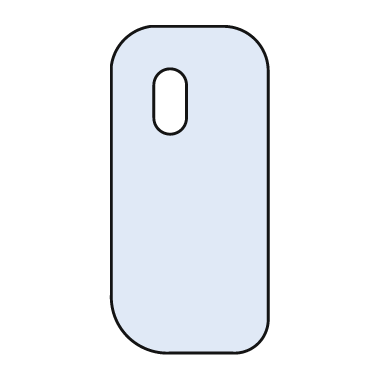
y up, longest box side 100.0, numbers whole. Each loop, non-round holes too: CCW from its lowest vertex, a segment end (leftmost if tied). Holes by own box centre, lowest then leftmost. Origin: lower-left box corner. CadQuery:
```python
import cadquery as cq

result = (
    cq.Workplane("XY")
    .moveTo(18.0, 0.0)
    .lineTo(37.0, 0.0)
    .threePointArc((45.0, 3.0), (48.0, 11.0))
    .lineTo(48.0, 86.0)
    .threePointArc((44.0, 96.0), (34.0, 100.0))
    .lineTo(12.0, 100.0)
    .threePointArc((4.0, 96.0), (0.0, 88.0))
    .lineTo(0.0, 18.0)
    .threePointArc((5.0, 5.0), (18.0, 0.0))
    .close()
    .moveTo(13.0, 72.0)
    .threePointArc((18.0, 67.0), (23.0, 72.0))
    .lineTo(23.0, 82.0)
    .threePointArc((18.0, 87.0), (13.0, 82.0))
    .close()
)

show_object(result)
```